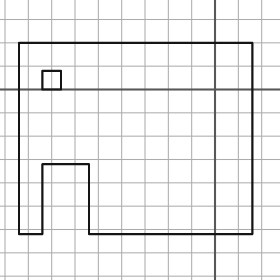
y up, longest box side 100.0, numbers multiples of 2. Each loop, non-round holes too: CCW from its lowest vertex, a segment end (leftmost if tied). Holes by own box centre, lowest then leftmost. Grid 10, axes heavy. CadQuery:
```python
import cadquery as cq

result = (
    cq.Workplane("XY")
    .moveTo(-84.0, -62.0)
    .lineTo(-74.0, -62.0)
    .lineTo(-74.0, -32.0)
    .lineTo(-54.0, -32.0)
    .lineTo(-54.0, -62.0)
    .lineTo(16.0, -62.0)
    .lineTo(16.0, 20.0)
    .lineTo(-84.0, 20.0)
    .close()
    .moveTo(-74.0, 0.0)
    .lineTo(-66.0, 0.0)
    .lineTo(-66.0, 8.0)
    .lineTo(-74.0, 8.0)
    .close()
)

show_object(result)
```